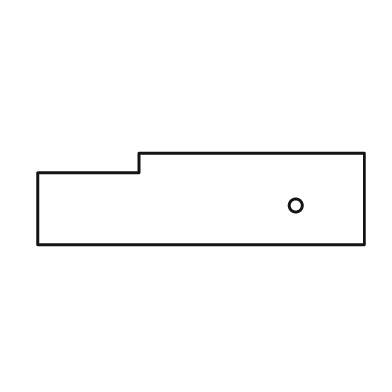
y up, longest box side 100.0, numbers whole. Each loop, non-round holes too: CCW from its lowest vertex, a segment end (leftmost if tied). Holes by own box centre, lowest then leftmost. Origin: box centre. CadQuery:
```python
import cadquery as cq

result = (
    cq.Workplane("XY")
    .moveTo(-50.0, -14.0)
    .lineTo(50.0, -14.0)
    .lineTo(50.0, 14.0)
    .lineTo(-19.0, 14.0)
    .lineTo(-19.0, 8.0)
    .lineTo(-50.0, 8.0)
    .close()
    .moveTo(29.0, -2.0)
    .circle(2.0)
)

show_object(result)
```